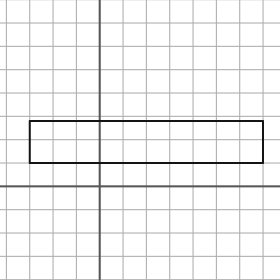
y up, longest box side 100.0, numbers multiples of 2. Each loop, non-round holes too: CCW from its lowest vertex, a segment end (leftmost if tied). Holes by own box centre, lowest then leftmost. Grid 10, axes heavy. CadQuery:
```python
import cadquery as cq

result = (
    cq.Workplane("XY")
    .moveTo(-30.0, 10.0)
    .lineTo(70.0, 10.0)
    .lineTo(70.0, 28.0)
    .lineTo(-30.0, 28.0)
    .close()
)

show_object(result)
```